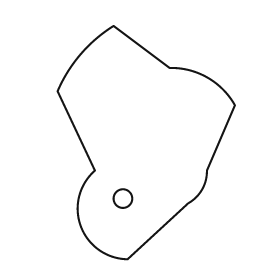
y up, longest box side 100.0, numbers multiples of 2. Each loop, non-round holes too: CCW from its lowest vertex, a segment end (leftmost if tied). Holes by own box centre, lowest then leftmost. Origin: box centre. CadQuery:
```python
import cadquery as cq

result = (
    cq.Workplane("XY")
    .moveTo(-8.0, -50.0)
    .lineTo(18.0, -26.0)
    .threePointArc((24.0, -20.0), (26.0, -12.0))
    .lineTo(38.0, 16.0)
    .threePointArc((26.0, 28.0), (10.0, 32.0))
    .lineTo(-14.0, 50.0)
    .threePointArc((-28.0, 38.0), (-38.0, 22.0))
    .lineTo(-22.0, -12.0)
    .threePointArc((-28.0, -36.0), (-8.0, -50.0))
    .close()
    .moveTo(-10.0, -24.0)
    .circle(4.0)
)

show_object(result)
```